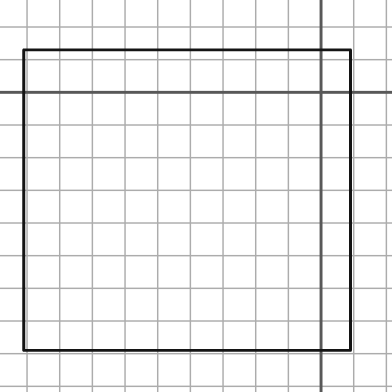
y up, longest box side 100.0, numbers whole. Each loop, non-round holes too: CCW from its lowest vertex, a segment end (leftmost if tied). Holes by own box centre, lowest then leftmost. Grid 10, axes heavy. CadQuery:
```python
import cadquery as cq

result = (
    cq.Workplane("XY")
    .moveTo(-91.0, -79.0)
    .lineTo(9.0, -79.0)
    .lineTo(9.0, 13.0)
    .lineTo(-91.0, 13.0)
    .close()
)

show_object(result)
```